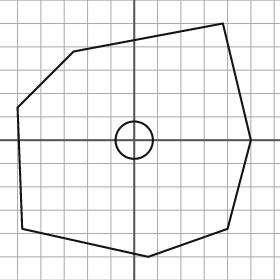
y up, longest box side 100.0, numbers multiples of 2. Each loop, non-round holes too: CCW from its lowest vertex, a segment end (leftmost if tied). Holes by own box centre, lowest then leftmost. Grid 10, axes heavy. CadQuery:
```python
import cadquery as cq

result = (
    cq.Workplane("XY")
    .moveTo(6.0, -50.0)
    .lineTo(40.0, -38.0)
    .lineTo(50.0, 0.0)
    .lineTo(38.0, 50.0)
    .lineTo(-26.0, 38.0)
    .lineTo(-50.0, 14.0)
    .lineTo(-48.0, -38.0)
    .close()
    .moveTo(0.0, 0.0)
    .circle(8.0)
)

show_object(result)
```